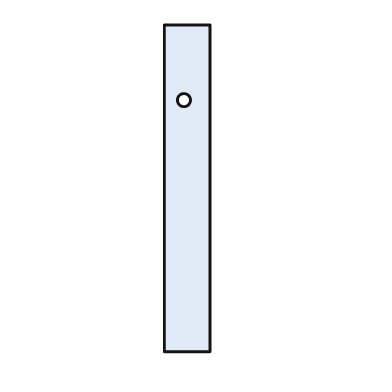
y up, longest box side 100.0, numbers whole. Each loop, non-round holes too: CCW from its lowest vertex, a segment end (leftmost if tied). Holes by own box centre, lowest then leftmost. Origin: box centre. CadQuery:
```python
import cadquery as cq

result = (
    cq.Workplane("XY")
    .moveTo(-7.0, -50.0)
    .lineTo(7.0, -50.0)
    .lineTo(7.0, 50.0)
    .lineTo(-7.0, 50.0)
    .close()
    .moveTo(-1.0, 27.0)
    .circle(2.0)
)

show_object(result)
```